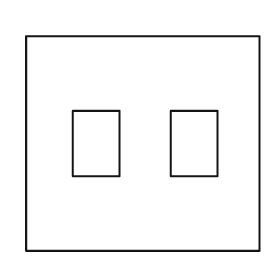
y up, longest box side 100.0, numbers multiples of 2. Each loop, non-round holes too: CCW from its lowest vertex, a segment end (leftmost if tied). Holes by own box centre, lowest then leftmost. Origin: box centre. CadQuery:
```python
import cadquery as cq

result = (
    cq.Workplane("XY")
    .moveTo(-50.0, -46.0)
    .lineTo(50.0, -46.0)
    .lineTo(50.0, 46.0)
    .lineTo(-50.0, 46.0)
    .close()
    .moveTo(-30.0, -14.0)
    .lineTo(-10.0, -14.0)
    .lineTo(-10.0, 14.0)
    .lineTo(-30.0, 14.0)
    .close()
    .moveTo(12.0, -14.0)
    .lineTo(32.0, -14.0)
    .lineTo(32.0, 14.0)
    .lineTo(12.0, 14.0)
    .close()
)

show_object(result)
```